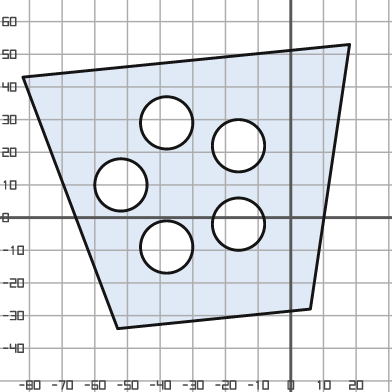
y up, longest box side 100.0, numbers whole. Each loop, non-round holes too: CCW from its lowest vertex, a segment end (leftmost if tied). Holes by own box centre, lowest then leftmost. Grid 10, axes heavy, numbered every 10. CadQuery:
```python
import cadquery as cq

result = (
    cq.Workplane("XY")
    .moveTo(-53.0, -34.0)
    .lineTo(6.0, -28.0)
    .lineTo(18.0, 53.0)
    .lineTo(-82.0, 43.0)
    .close()
    .moveTo(-38.0, -9.0)
    .circle(8.0)
    .moveTo(-16.0, -2.0)
    .circle(8.0)
    .moveTo(-52.0, 10.0)
    .circle(8.0)
    .moveTo(-16.0, 22.0)
    .circle(8.0)
    .moveTo(-38.0, 29.0)
    .circle(8.0)
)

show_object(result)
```